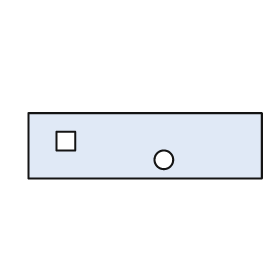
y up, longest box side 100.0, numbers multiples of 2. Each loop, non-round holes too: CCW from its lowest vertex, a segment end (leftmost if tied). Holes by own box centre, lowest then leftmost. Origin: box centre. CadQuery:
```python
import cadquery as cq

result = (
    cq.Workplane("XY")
    .moveTo(-50.0, -14.0)
    .lineTo(50.0, -14.0)
    .lineTo(50.0, 14.0)
    .lineTo(-50.0, 14.0)
    .close()
    .moveTo(8.0, -6.0)
    .circle(4.0)
    .moveTo(-38.0, -2.0)
    .lineTo(-30.0, -2.0)
    .lineTo(-30.0, 6.0)
    .lineTo(-38.0, 6.0)
    .close()
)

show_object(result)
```